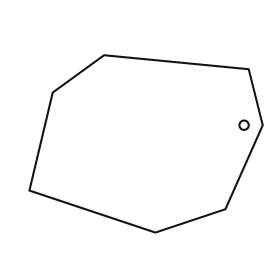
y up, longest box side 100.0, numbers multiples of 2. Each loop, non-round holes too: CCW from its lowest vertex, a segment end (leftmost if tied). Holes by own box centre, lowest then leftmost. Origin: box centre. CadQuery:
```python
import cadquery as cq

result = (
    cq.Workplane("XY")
    .moveTo(4.0, -38.0)
    .lineTo(34.0, -28.0)
    .lineTo(50.0, 8.0)
    .lineTo(44.0, 32.0)
    .lineTo(-18.0, 38.0)
    .lineTo(-40.0, 22.0)
    .lineTo(-50.0, -20.0)
    .close()
    .moveTo(42.0, 8.0)
    .circle(2.0)
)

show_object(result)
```